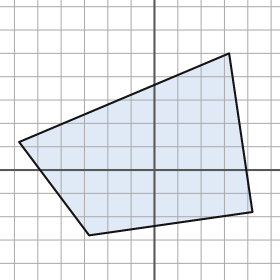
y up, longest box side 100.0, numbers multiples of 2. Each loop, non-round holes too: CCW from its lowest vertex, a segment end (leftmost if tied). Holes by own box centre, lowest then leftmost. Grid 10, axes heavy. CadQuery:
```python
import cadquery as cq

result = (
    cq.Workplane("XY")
    .moveTo(-28.0, -28.0)
    .lineTo(42.0, -18.0)
    .lineTo(32.0, 50.0)
    .lineTo(-58.0, 12.0)
    .close()
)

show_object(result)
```